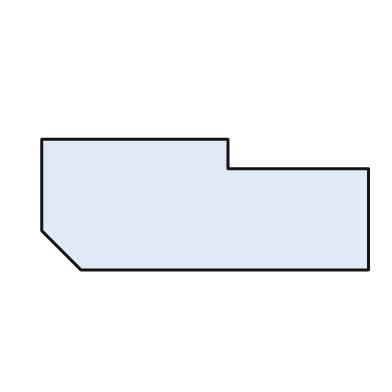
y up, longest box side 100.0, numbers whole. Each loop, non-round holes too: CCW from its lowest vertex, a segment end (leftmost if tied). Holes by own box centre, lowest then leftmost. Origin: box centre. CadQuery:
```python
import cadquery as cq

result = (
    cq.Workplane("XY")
    .moveTo(-38.0, -20.0)
    .lineTo(50.0, -20.0)
    .lineTo(50.0, 11.0)
    .lineTo(7.0, 11.0)
    .lineTo(7.0, 20.0)
    .lineTo(-50.0, 20.0)
    .lineTo(-50.0, -8.0)
    .close()
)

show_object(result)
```